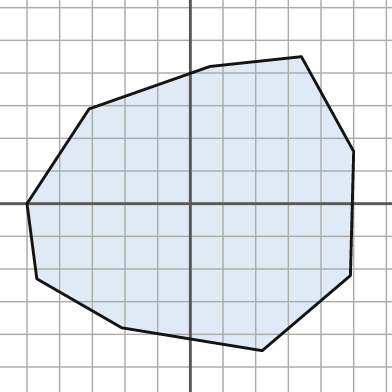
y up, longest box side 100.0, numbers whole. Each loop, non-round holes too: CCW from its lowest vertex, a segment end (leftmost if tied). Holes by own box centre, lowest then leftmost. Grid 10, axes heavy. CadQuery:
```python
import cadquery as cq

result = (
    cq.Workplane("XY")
    .moveTo(22.0, -45.0)
    .lineTo(49.0, -22.0)
    .lineTo(50.0, 16.0)
    .lineTo(34.0, 45.0)
    .lineTo(6.0, 42.0)
    .lineTo(-31.0, 29.0)
    .lineTo(-50.0, 0.0)
    .lineTo(-47.0, -23.0)
    .lineTo(-21.0, -38.0)
    .close()
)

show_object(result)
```